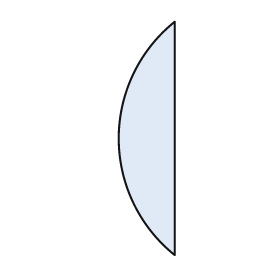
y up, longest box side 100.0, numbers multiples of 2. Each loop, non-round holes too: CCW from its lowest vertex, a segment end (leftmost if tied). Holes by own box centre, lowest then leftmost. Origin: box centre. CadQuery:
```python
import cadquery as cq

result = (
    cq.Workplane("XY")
    .moveTo(12.0, -50.0)
    .lineTo(12.0, 50.0)
    .threePointArc((-12.0, 0.0), (12.0, -50.0))
    .close()
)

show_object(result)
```